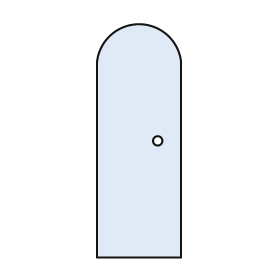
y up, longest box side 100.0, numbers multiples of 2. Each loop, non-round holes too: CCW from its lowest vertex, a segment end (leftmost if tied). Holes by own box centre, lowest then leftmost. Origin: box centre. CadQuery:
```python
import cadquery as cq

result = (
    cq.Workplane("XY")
    .moveTo(-18.0, -50.0)
    .lineTo(18.0, -50.0)
    .lineTo(18.0, 34.0)
    .threePointArc((0.0, 50.0), (-18.0, 34.0))
    .close()
    .moveTo(8.0, 0.0)
    .circle(2.0)
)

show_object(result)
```